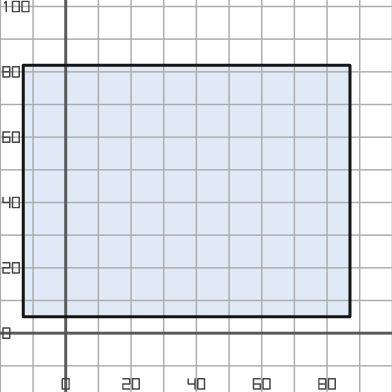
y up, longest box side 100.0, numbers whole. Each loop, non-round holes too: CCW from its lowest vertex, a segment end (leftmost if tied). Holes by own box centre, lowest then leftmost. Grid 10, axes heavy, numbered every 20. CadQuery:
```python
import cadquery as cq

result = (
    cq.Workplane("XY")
    .moveTo(-13.0, 5.0)
    .lineTo(87.0, 5.0)
    .lineTo(87.0, 82.0)
    .lineTo(-13.0, 82.0)
    .close()
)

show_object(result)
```